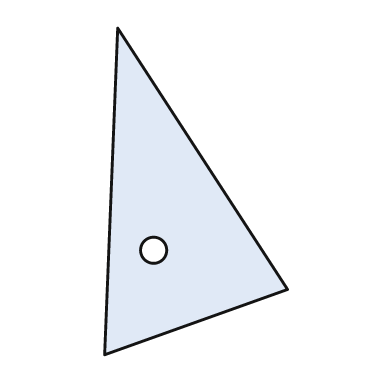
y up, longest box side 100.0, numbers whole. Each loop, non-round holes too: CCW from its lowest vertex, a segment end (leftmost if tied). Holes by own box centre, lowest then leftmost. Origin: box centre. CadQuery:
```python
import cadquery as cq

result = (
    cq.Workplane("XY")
    .moveTo(-28.0, -50.0)
    .lineTo(28.0, -30.0)
    .lineTo(-24.0, 50.0)
    .close()
    .moveTo(-13.0, -18.0)
    .circle(4.0)
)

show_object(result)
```